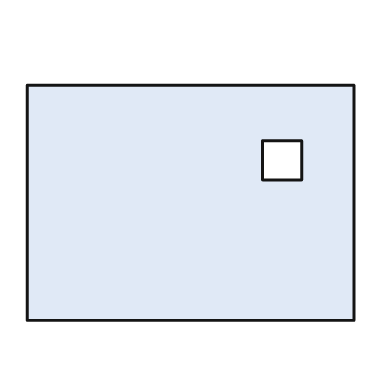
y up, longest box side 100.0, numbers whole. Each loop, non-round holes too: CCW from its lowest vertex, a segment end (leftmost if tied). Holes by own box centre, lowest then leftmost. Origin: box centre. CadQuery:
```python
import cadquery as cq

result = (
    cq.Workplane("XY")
    .moveTo(-50.0, -36.0)
    .lineTo(50.0, -36.0)
    .lineTo(50.0, 36.0)
    .lineTo(-50.0, 36.0)
    .close()
    .moveTo(22.0, 7.0)
    .lineTo(34.0, 7.0)
    .lineTo(34.0, 19.0)
    .lineTo(22.0, 19.0)
    .close()
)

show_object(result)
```